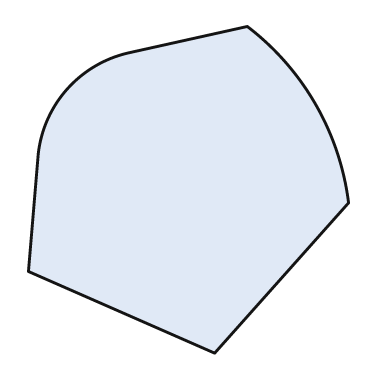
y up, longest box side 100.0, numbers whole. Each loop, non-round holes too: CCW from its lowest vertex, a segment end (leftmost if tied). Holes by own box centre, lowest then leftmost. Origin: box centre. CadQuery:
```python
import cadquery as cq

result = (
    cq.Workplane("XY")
    .moveTo(8.0, -50.0)
    .lineTo(49.0, -4.0)
    .threePointArc((39.0, 26.0), (18.0, 50.0))
    .lineTo(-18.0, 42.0)
    .threePointArc((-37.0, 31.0), (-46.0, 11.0))
    .lineTo(-49.0, -25.0)
    .close()
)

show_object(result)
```